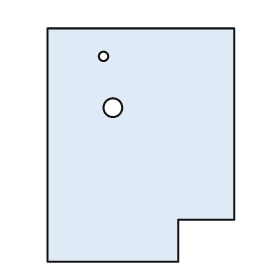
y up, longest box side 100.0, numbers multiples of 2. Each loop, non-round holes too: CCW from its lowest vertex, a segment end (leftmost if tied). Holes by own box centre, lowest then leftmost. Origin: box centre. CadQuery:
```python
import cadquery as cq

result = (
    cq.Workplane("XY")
    .moveTo(-40.0, -50.0)
    .lineTo(16.0, -50.0)
    .lineTo(16.0, -32.0)
    .lineTo(40.0, -32.0)
    .lineTo(40.0, 50.0)
    .lineTo(-40.0, 50.0)
    .close()
    .moveTo(-12.0, 16.0)
    .circle(4.0)
    .moveTo(-16.0, 38.0)
    .circle(2.0)
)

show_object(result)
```